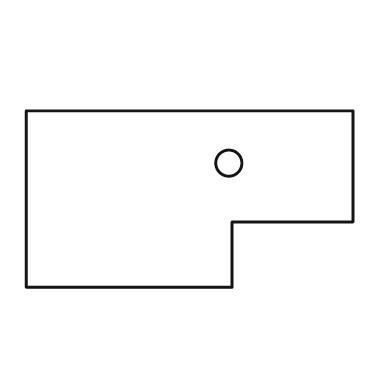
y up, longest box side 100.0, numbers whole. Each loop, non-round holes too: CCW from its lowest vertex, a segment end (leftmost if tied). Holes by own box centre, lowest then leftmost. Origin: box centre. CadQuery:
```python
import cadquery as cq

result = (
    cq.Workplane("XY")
    .moveTo(-50.0, -27.0)
    .lineTo(13.0, -27.0)
    .lineTo(13.0, -7.0)
    .lineTo(50.0, -7.0)
    .lineTo(50.0, 27.0)
    .lineTo(-50.0, 27.0)
    .close()
    .moveTo(12.0, 11.0)
    .circle(4.0)
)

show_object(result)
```